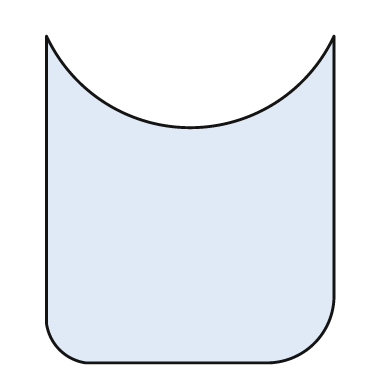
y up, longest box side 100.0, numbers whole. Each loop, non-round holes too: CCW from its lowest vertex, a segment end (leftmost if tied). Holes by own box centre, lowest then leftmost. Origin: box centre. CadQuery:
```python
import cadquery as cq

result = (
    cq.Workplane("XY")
    .moveTo(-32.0, -50.0)
    .lineTo(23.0, -50.0)
    .threePointArc((38.0, -44.0), (44.0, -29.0))
    .lineTo(44.0, 50.0)
    .threePointArc((0.0, 22.0), (-44.0, 50.0))
    .lineTo(-44.0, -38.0)
    .threePointArc((-40.0, -46.0), (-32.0, -50.0))
    .close()
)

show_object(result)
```